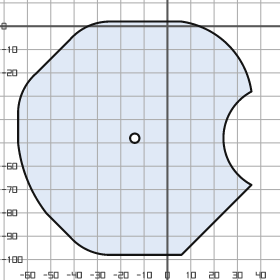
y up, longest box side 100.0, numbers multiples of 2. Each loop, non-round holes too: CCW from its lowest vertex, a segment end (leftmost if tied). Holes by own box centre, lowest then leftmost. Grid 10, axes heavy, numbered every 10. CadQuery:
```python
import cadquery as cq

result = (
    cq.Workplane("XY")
    .moveTo(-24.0, -98.0)
    .lineTo(6.0, -98.0)
    .lineTo(36.0, -68.0)
    .threePointArc((24.0, -48.0), (36.0, -28.0))
    .threePointArc((26.0, -8.0), (6.0, 2.0))
    .lineTo(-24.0, 2.0)
    .threePointArc((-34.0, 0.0), (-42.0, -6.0))
    .lineTo(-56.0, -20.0)
    .threePointArc((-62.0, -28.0), (-64.0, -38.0))
    .lineTo(-64.0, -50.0)
    .threePointArc((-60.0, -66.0), (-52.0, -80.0))
    .lineTo(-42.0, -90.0)
    .threePointArc((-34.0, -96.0), (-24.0, -98.0))
    .close()
    .moveTo(-14.0, -48.0)
    .circle(2.0)
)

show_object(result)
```